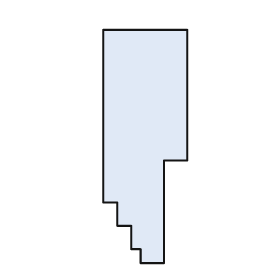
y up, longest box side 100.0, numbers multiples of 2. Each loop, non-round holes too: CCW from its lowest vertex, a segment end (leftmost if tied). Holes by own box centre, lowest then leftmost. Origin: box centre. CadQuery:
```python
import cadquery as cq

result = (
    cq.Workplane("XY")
    .moveTo(-2.0, -50.0)
    .lineTo(8.0, -50.0)
    .lineTo(8.0, -6.0)
    .lineTo(18.0, -6.0)
    .lineTo(18.0, 50.0)
    .lineTo(-18.0, 50.0)
    .lineTo(-18.0, -24.0)
    .lineTo(-12.0, -24.0)
    .lineTo(-12.0, -34.0)
    .lineTo(-6.0, -34.0)
    .lineTo(-6.0, -44.0)
    .lineTo(-2.0, -44.0)
    .close()
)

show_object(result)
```